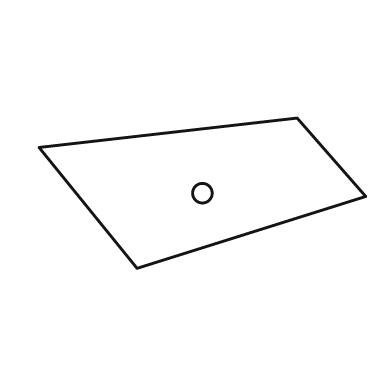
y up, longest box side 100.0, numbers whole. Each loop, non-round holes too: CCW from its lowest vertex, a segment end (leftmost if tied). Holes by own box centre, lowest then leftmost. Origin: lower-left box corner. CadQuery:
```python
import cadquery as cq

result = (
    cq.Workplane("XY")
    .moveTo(30.0, 0.0)
    .lineTo(100.0, 22.0)
    .lineTo(79.0, 46.0)
    .lineTo(0.0, 37.0)
    .close()
    .moveTo(50.0, 23.0)
    .circle(3.0)
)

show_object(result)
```